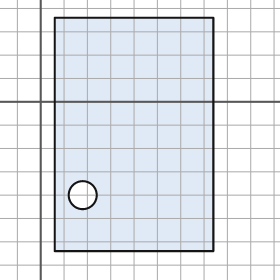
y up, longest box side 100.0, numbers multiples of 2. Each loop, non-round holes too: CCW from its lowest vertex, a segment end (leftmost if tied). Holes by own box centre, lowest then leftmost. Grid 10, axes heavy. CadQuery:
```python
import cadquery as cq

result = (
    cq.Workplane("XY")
    .moveTo(6.0, -64.0)
    .lineTo(74.0, -64.0)
    .lineTo(74.0, 36.0)
    .lineTo(6.0, 36.0)
    .close()
    .moveTo(18.0, -40.0)
    .circle(6.0)
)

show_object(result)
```